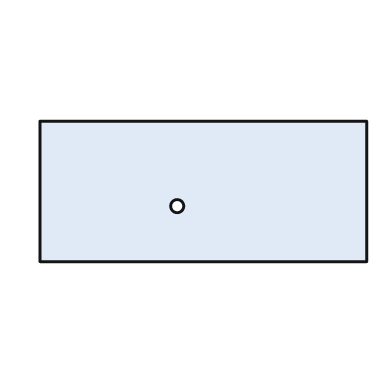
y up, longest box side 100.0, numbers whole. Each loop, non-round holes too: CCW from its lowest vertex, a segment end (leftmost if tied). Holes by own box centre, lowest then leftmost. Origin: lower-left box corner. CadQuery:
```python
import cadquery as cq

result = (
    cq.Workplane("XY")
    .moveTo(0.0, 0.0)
    .lineTo(100.0, 0.0)
    .lineTo(100.0, 43.0)
    .lineTo(0.0, 43.0)
    .close()
    .moveTo(42.0, 17.0)
    .circle(2.0)
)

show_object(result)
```